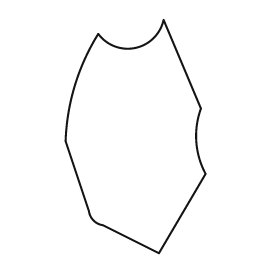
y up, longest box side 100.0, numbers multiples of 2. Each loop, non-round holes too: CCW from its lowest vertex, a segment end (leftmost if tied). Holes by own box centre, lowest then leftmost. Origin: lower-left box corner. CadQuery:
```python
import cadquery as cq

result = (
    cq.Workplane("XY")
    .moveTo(40.0, 0.0)
    .lineTo(60.0, 34.0)
    .threePointArc((56.0, 48.0), (58.0, 62.0))
    .lineTo(42.0, 100.0)
    .threePointArc((30.0, 88.0), (14.0, 94.0))
    .threePointArc((4.0, 72.0), (0.0, 48.0))
    .lineTo(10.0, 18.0)
    .threePointArc((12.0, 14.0), (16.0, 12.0))
    .close()
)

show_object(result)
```